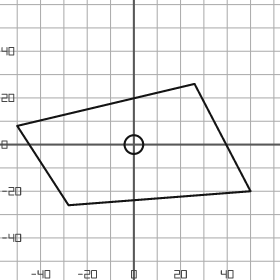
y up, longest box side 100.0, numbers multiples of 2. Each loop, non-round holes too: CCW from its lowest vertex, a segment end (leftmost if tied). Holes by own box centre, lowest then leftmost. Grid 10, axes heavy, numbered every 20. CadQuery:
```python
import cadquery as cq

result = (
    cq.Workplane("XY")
    .moveTo(-28.0, -26.0)
    .lineTo(50.0, -20.0)
    .lineTo(26.0, 26.0)
    .lineTo(-50.0, 8.0)
    .close()
    .moveTo(0.0, 0.0)
    .circle(4.0)
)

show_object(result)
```